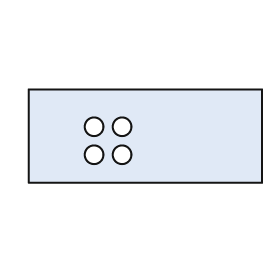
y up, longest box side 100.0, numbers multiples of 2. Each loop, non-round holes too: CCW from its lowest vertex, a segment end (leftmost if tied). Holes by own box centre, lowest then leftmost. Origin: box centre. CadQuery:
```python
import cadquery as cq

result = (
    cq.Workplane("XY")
    .moveTo(-50.0, -20.0)
    .lineTo(50.0, -20.0)
    .lineTo(50.0, 20.0)
    .lineTo(-50.0, 20.0)
    .close()
    .moveTo(-22.0, -8.0)
    .circle(4.0)
    .moveTo(-10.0, -8.0)
    .circle(4.0)
    .moveTo(-22.0, 4.0)
    .circle(4.0)
    .moveTo(-10.0, 4.0)
    .circle(4.0)
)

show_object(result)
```